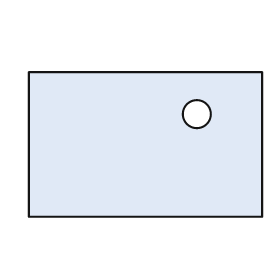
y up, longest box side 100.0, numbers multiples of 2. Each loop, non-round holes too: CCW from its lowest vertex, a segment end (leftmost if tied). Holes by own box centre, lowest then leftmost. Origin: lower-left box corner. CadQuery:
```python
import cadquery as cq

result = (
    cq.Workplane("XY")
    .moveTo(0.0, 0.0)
    .lineTo(100.0, 0.0)
    .lineTo(100.0, 62.0)
    .lineTo(0.0, 62.0)
    .close()
    .moveTo(72.0, 44.0)
    .circle(6.0)
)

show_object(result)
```